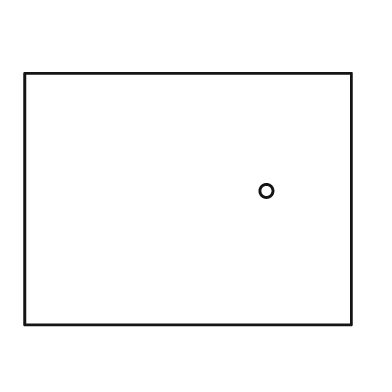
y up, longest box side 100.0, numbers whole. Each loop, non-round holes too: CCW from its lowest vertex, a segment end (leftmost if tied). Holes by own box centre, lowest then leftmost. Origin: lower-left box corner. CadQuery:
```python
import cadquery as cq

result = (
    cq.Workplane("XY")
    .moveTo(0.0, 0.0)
    .lineTo(100.0, 0.0)
    .lineTo(100.0, 77.0)
    .lineTo(0.0, 77.0)
    .close()
    .moveTo(74.0, 41.0)
    .circle(2.0)
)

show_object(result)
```